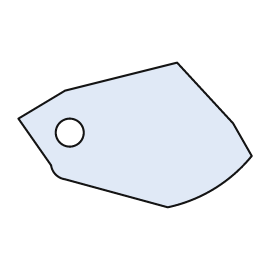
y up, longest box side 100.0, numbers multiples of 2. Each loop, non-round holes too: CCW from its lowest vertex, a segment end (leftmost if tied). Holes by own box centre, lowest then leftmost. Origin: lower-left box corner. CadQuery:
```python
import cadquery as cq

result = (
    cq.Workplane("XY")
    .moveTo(64.0, 0.0)
    .threePointArc((84.0, 8.0), (100.0, 22.0))
    .lineTo(92.0, 36.0)
    .lineTo(68.0, 62.0)
    .lineTo(20.0, 50.0)
    .lineTo(0.0, 38.0)
    .lineTo(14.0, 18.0)
    .threePointArc((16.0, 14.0), (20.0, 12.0))
    .close()
    .moveTo(22.0, 32.0)
    .circle(6.0)
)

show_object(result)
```